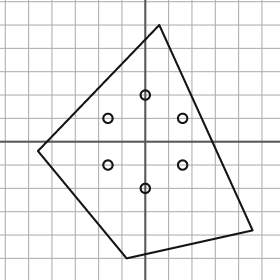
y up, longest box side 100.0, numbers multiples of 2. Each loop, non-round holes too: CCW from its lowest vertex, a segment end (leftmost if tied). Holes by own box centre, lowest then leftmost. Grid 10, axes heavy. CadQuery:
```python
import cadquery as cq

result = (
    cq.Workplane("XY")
    .moveTo(-8.0, -50.0)
    .lineTo(46.0, -38.0)
    .lineTo(6.0, 50.0)
    .lineTo(-46.0, -4.0)
    .close()
    .moveTo(0.0, -20.0)
    .circle(2.0)
    .moveTo(-16.0, -10.0)
    .circle(2.0)
    .moveTo(16.0, -10.0)
    .circle(2.0)
    .moveTo(-16.0, 10.0)
    .circle(2.0)
    .moveTo(16.0, 10.0)
    .circle(2.0)
    .moveTo(0.0, 20.0)
    .circle(2.0)
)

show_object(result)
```